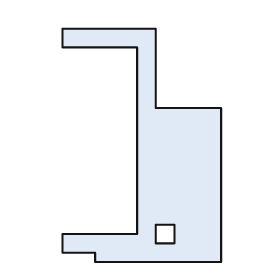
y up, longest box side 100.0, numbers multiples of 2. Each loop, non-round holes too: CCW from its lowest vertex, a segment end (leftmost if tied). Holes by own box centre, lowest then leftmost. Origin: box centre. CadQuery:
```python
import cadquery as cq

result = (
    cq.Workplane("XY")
    .moveTo(-20.0, -50.0)
    .lineTo(34.0, -50.0)
    .lineTo(34.0, 16.0)
    .lineTo(6.0, 16.0)
    .lineTo(6.0, 50.0)
    .lineTo(-34.0, 50.0)
    .lineTo(-34.0, 42.0)
    .lineTo(-2.0, 42.0)
    .lineTo(-2.0, -38.0)
    .lineTo(-34.0, -38.0)
    .lineTo(-34.0, -46.0)
    .lineTo(-20.0, -46.0)
    .close()
    .moveTo(6.0, -42.0)
    .lineTo(14.0, -42.0)
    .lineTo(14.0, -34.0)
    .lineTo(6.0, -34.0)
    .close()
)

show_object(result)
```